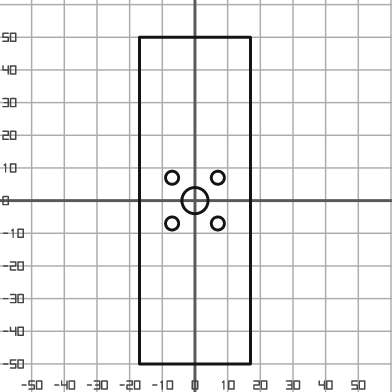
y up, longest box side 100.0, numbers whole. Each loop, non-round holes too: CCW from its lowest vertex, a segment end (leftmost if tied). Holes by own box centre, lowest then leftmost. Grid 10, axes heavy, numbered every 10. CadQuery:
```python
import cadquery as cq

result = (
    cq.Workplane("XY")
    .moveTo(-17.0, -50.0)
    .lineTo(17.0, -50.0)
    .lineTo(17.0, 50.0)
    .lineTo(-17.0, 50.0)
    .close()
    .moveTo(-7.0, -7.0)
    .circle(2.0)
    .moveTo(7.0, -7.0)
    .circle(2.0)
    .moveTo(0.0, 0.0)
    .circle(4.0)
    .moveTo(-7.0, 7.0)
    .circle(2.0)
    .moveTo(7.0, 7.0)
    .circle(2.0)
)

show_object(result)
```